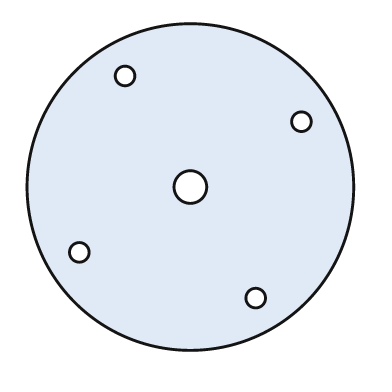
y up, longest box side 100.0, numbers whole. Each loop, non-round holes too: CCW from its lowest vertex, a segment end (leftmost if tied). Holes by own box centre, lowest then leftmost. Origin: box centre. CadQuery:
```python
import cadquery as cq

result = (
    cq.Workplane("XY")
    .moveTo(0.0, 0.0)
    .circle(50.0)
    .moveTo(20.0, -34.0)
    .circle(3.0)
    .moveTo(-34.0, -20.0)
    .circle(3.0)
    .moveTo(0.0, 0.0)
    .circle(5.0)
    .moveTo(34.0, 20.0)
    .circle(3.0)
    .moveTo(-20.0, 34.0)
    .circle(3.0)
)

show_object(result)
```